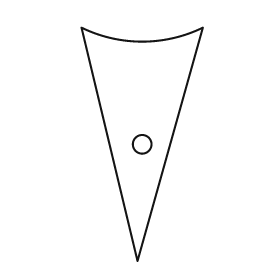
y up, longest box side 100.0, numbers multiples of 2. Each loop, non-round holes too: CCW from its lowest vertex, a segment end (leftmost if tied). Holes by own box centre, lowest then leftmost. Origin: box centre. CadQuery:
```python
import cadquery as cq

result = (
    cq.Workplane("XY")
    .moveTo(-2.0, -50.0)
    .lineTo(26.0, 50.0)
    .threePointArc((0.0, 44.0), (-26.0, 50.0))
    .close()
    .moveTo(0.0, 0.0)
    .circle(4.0)
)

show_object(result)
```